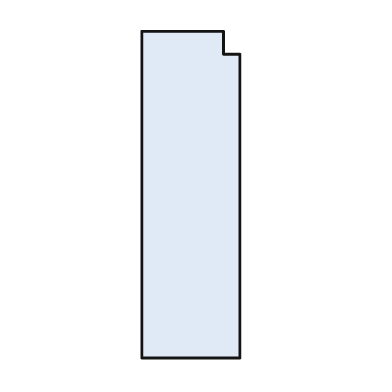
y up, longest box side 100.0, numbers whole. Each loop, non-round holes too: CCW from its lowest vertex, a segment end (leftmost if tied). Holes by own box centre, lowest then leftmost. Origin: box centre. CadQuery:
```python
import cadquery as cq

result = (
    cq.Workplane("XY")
    .moveTo(-15.0, -50.0)
    .lineTo(15.0, -50.0)
    .lineTo(15.0, 43.0)
    .lineTo(10.0, 43.0)
    .lineTo(10.0, 50.0)
    .lineTo(-15.0, 50.0)
    .close()
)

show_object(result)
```